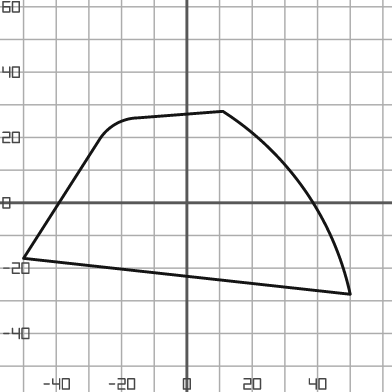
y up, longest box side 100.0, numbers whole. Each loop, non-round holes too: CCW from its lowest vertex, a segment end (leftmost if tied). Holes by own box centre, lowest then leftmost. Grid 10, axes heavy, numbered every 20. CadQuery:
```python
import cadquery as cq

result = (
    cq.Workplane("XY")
    .moveTo(50.0, -28.0)
    .threePointArc((36.0, 4.0), (11.0, 28.0))
    .lineTo(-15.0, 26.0)
    .threePointArc((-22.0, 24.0), (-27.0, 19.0))
    .lineTo(-50.0, -17.0)
    .close()
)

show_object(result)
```